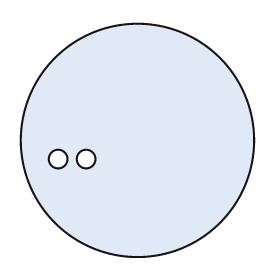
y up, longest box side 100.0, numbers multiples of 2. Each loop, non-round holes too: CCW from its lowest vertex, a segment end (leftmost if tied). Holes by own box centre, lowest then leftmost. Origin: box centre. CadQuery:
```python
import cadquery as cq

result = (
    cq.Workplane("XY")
    .moveTo(0.0, 0.0)
    .circle(50.0)
    .moveTo(-34.0, -8.0)
    .circle(4.0)
    .moveTo(-22.0, -8.0)
    .circle(4.0)
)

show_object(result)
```